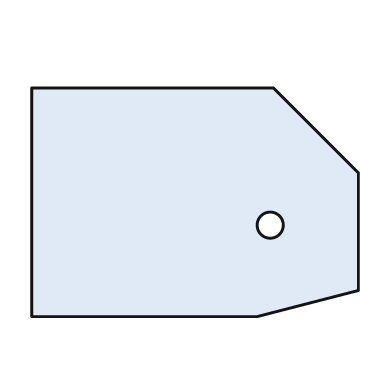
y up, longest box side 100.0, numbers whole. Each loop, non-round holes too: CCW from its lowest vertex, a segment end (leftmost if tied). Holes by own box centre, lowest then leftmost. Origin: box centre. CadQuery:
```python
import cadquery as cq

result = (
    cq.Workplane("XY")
    .moveTo(-50.0, -35.0)
    .lineTo(19.0, -35.0)
    .lineTo(50.0, -27.0)
    .lineTo(50.0, 9.0)
    .lineTo(24.0, 35.0)
    .lineTo(-50.0, 35.0)
    .close()
    .moveTo(23.0, -7.0)
    .circle(4.0)
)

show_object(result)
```